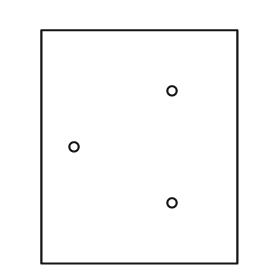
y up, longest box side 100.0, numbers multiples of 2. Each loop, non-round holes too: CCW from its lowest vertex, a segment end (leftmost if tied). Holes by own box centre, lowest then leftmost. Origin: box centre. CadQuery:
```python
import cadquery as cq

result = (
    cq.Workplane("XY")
    .moveTo(-42.0, -50.0)
    .lineTo(42.0, -50.0)
    .lineTo(42.0, 50.0)
    .lineTo(-42.0, 50.0)
    .close()
    .moveTo(14.0, -24.0)
    .circle(2.0)
    .moveTo(-28.0, 0.0)
    .circle(2.0)
    .moveTo(14.0, 24.0)
    .circle(2.0)
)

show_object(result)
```